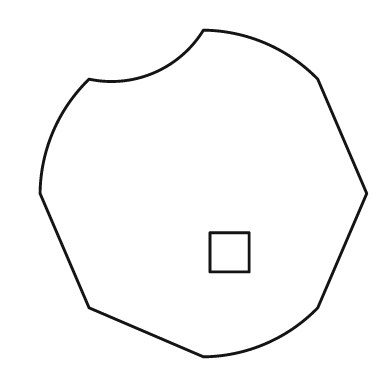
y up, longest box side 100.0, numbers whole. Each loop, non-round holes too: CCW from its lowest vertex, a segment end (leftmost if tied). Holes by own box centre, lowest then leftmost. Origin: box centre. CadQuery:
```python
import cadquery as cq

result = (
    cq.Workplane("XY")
    .moveTo(0.0, -50.0)
    .threePointArc((19.0, -46.0), (35.0, -35.0))
    .lineTo(50.0, 0.0)
    .lineTo(35.0, 35.0)
    .threePointArc((19.0, 46.0), (0.0, 50.0))
    .threePointArc((-15.0, 37.0), (-35.0, 35.0))
    .threePointArc((-46.0, 19.0), (-50.0, 0.0))
    .lineTo(-35.0, -35.0)
    .close()
    .moveTo(2.0, -24.0)
    .lineTo(14.0, -24.0)
    .lineTo(14.0, -12.0)
    .lineTo(2.0, -12.0)
    .close()
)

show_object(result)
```